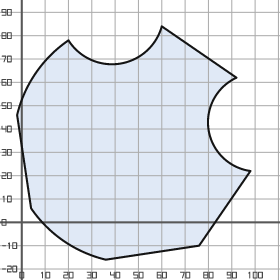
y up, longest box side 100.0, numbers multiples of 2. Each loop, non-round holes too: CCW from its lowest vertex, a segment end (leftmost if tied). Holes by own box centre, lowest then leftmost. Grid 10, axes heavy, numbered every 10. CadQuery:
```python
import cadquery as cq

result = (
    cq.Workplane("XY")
    .moveTo(36.0, -16.0)
    .lineTo(76.0, -10.0)
    .lineTo(98.0, 22.0)
    .threePointArc((80.0, 40.0), (92.0, 62.0))
    .lineTo(60.0, 84.0)
    .threePointArc((42.0, 68.0), (20.0, 78.0))
    .threePointArc((6.0, 64.0), (-2.0, 46.0))
    .lineTo(4.0, 6.0)
    .threePointArc((18.0, -8.0), (36.0, -16.0))
    .close()
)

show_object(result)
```